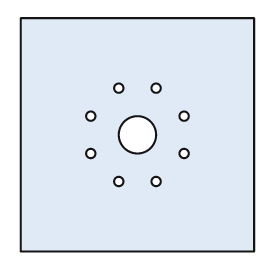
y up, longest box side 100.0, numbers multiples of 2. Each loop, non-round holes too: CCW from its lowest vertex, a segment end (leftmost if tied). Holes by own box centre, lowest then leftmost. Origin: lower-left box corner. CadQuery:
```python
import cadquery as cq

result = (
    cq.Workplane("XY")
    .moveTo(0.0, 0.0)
    .lineTo(100.0, 0.0)
    .lineTo(100.0, 100.0)
    .lineTo(0.0, 100.0)
    .close()
    .moveTo(42.0, 30.0)
    .circle(2.0)
    .moveTo(58.0, 30.0)
    .circle(2.0)
    .moveTo(30.0, 42.0)
    .circle(2.0)
    .moveTo(70.0, 42.0)
    .circle(2.0)
    .moveTo(50.0, 50.0)
    .circle(8.0)
    .moveTo(30.0, 58.0)
    .circle(2.0)
    .moveTo(70.0, 58.0)
    .circle(2.0)
    .moveTo(42.0, 70.0)
    .circle(2.0)
    .moveTo(58.0, 70.0)
    .circle(2.0)
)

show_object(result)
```